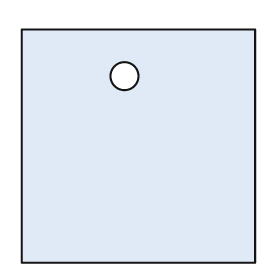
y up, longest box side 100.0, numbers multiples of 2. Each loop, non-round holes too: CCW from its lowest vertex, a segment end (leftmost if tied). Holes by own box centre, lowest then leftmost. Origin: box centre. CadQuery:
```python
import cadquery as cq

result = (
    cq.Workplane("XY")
    .moveTo(-50.0, -50.0)
    .lineTo(50.0, -50.0)
    .lineTo(50.0, 50.0)
    .lineTo(-50.0, 50.0)
    .close()
    .moveTo(-6.0, 30.0)
    .circle(6.0)
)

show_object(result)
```